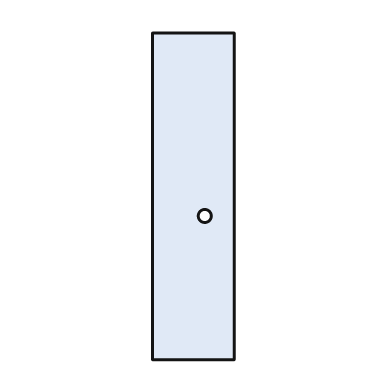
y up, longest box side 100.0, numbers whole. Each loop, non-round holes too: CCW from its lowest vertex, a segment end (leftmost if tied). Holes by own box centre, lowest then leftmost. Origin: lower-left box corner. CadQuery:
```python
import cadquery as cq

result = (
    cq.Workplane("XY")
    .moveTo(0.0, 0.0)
    .lineTo(25.0, 0.0)
    .lineTo(25.0, 100.0)
    .lineTo(0.0, 100.0)
    .close()
    .moveTo(16.0, 44.0)
    .circle(2.0)
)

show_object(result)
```